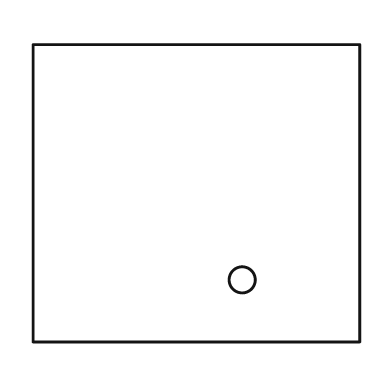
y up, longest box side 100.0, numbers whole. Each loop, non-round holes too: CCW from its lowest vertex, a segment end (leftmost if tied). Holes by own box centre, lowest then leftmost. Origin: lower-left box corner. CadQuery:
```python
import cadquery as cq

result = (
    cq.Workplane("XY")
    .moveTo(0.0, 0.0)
    .lineTo(100.0, 0.0)
    .lineTo(100.0, 91.0)
    .lineTo(0.0, 91.0)
    .close()
    .moveTo(64.0, 19.0)
    .circle(4.0)
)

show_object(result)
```